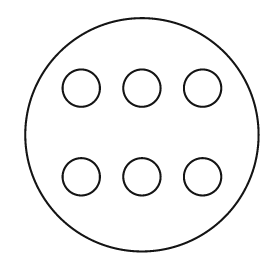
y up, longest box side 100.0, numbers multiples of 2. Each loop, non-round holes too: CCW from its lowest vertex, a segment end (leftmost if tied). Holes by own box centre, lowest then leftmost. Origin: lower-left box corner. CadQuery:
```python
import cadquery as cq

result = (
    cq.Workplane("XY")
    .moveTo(50.0, 50.0)
    .circle(50.0)
    .moveTo(24.0, 32.0)
    .circle(8.0)
    .moveTo(50.0, 32.0)
    .circle(8.0)
    .moveTo(76.0, 32.0)
    .circle(8.0)
    .moveTo(24.0, 70.0)
    .circle(8.0)
    .moveTo(50.0, 70.0)
    .circle(8.0)
    .moveTo(76.0, 70.0)
    .circle(8.0)
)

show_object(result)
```